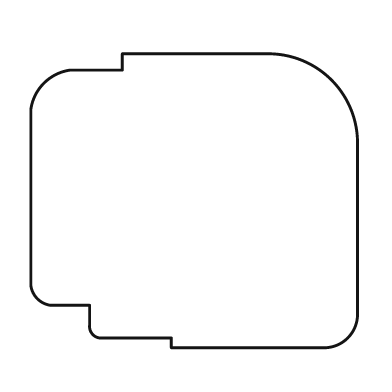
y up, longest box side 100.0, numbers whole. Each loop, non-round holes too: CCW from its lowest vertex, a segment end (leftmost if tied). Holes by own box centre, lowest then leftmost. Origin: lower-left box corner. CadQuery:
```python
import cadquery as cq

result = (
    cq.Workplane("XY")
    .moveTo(43.0, 0.0)
    .lineTo(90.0, 0.0)
    .threePointArc((97.0, 3.0), (100.0, 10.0))
    .lineTo(100.0, 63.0)
    .threePointArc((92.0, 82.0), (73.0, 90.0))
    .lineTo(28.0, 90.0)
    .lineTo(28.0, 85.0)
    .lineTo(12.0, 85.0)
    .threePointArc((4.0, 81.0), (0.0, 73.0))
    .lineTo(0.0, 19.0)
    .threePointArc((2.0, 15.0), (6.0, 13.0))
    .lineTo(18.0, 13.0)
    .lineTo(18.0, 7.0)
    .threePointArc((19.0, 4.0), (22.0, 3.0))
    .lineTo(43.0, 3.0)
    .close()
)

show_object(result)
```